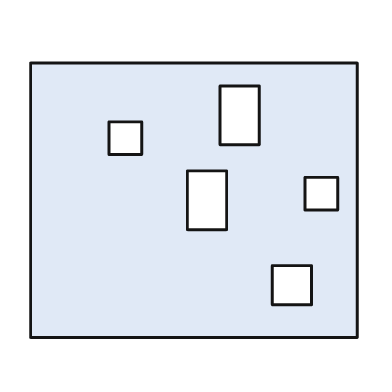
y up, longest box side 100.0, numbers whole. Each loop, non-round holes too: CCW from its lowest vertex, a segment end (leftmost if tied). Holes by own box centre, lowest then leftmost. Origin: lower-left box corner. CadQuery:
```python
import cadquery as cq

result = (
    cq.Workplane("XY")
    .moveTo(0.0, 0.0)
    .lineTo(100.0, 0.0)
    .lineTo(100.0, 84.0)
    .lineTo(0.0, 84.0)
    .close()
    .moveTo(74.0, 10.0)
    .lineTo(86.0, 10.0)
    .lineTo(86.0, 22.0)
    .lineTo(74.0, 22.0)
    .close()
    .moveTo(48.0, 33.0)
    .lineTo(60.0, 33.0)
    .lineTo(60.0, 51.0)
    .lineTo(48.0, 51.0)
    .close()
    .moveTo(84.0, 39.0)
    .lineTo(94.0, 39.0)
    .lineTo(94.0, 49.0)
    .lineTo(84.0, 49.0)
    .close()
    .moveTo(24.0, 56.0)
    .lineTo(34.0, 56.0)
    .lineTo(34.0, 66.0)
    .lineTo(24.0, 66.0)
    .close()
    .moveTo(58.0, 59.0)
    .lineTo(70.0, 59.0)
    .lineTo(70.0, 77.0)
    .lineTo(58.0, 77.0)
    .close()
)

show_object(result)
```